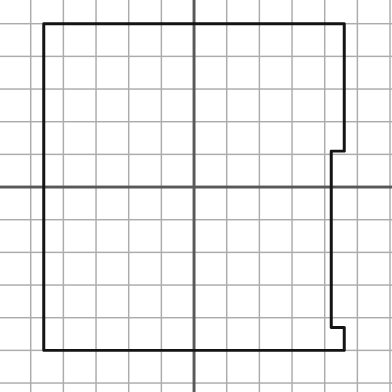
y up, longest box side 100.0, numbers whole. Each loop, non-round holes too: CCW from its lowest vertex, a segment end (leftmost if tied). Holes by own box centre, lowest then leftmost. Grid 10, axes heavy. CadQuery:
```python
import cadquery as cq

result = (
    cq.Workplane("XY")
    .moveTo(-46.0, -50.0)
    .lineTo(46.0, -50.0)
    .lineTo(46.0, -43.0)
    .lineTo(42.0, -43.0)
    .lineTo(42.0, 11.0)
    .lineTo(46.0, 11.0)
    .lineTo(46.0, 50.0)
    .lineTo(-46.0, 50.0)
    .close()
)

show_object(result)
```